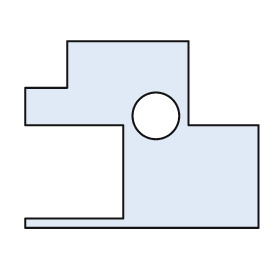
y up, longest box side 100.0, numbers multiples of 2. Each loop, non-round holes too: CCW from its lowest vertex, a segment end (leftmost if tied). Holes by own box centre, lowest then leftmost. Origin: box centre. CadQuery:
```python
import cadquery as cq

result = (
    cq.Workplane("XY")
    .moveTo(-50.0, -40.0)
    .lineTo(50.0, -40.0)
    .lineTo(50.0, 4.0)
    .lineTo(20.0, 4.0)
    .lineTo(20.0, 40.0)
    .lineTo(-32.0, 40.0)
    .lineTo(-32.0, 20.0)
    .lineTo(-50.0, 20.0)
    .lineTo(-50.0, 4.0)
    .lineTo(-8.0, 4.0)
    .lineTo(-8.0, -36.0)
    .lineTo(-50.0, -36.0)
    .close()
    .moveTo(6.0, 8.0)
    .circle(10.0)
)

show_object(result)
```